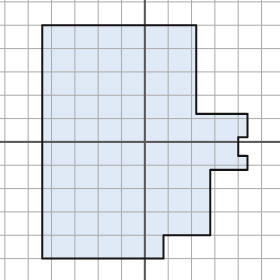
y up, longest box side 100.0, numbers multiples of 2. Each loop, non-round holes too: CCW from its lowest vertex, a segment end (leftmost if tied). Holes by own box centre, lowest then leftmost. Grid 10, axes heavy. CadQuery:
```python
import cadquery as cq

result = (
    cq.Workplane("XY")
    .moveTo(-44.0, -50.0)
    .lineTo(8.0, -50.0)
    .lineTo(8.0, -40.0)
    .lineTo(28.0, -40.0)
    .lineTo(28.0, -12.0)
    .lineTo(44.0, -12.0)
    .lineTo(44.0, -6.0)
    .lineTo(40.0, -6.0)
    .lineTo(40.0, 2.0)
    .lineTo(44.0, 2.0)
    .lineTo(44.0, 12.0)
    .lineTo(22.0, 12.0)
    .lineTo(22.0, 50.0)
    .lineTo(-44.0, 50.0)
    .close()
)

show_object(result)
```